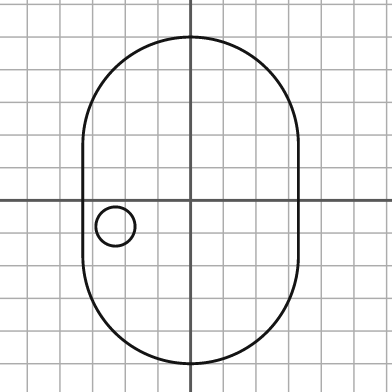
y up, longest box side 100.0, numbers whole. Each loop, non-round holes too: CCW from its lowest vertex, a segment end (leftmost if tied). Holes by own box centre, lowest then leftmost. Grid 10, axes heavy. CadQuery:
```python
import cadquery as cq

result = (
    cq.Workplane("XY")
    .moveTo(-33.0, -17.0)
    .threePointArc((0.0, -50.0), (33.0, -17.0))
    .lineTo(33.0, 17.0)
    .threePointArc((0.0, 50.0), (-33.0, 17.0))
    .close()
    .moveTo(-23.0, -8.0)
    .circle(6.0)
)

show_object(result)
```